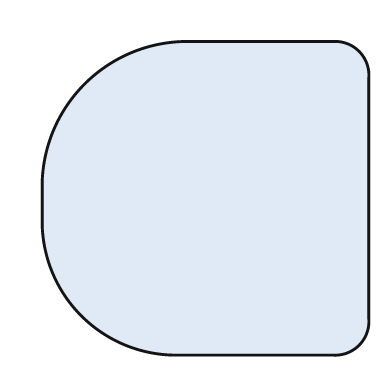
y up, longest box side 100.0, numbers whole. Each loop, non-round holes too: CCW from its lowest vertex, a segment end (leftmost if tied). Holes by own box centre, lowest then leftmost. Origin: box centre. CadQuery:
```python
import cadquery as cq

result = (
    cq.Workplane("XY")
    .moveTo(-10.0, -48.0)
    .lineTo(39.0, -48.0)
    .threePointArc((47.0, -45.0), (50.0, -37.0))
    .lineTo(50.0, 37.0)
    .threePointArc((47.0, 45.0), (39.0, 48.0))
    .lineTo(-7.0, 48.0)
    .threePointArc((-37.0, 35.0), (-50.0, 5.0))
    .lineTo(-50.0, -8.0)
    .threePointArc((-38.0, -36.0), (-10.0, -48.0))
    .close()
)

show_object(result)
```